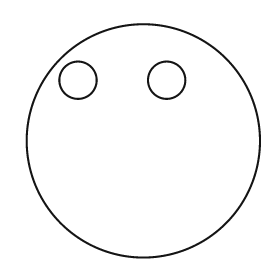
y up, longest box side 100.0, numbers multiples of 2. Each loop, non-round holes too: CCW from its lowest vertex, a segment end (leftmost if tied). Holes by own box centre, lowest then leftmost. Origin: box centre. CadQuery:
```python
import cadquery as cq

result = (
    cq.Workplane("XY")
    .moveTo(0.0, 0.0)
    .circle(50.0)
    .moveTo(-28.0, 26.0)
    .circle(8.0)
    .moveTo(10.0, 26.0)
    .circle(8.0)
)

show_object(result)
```